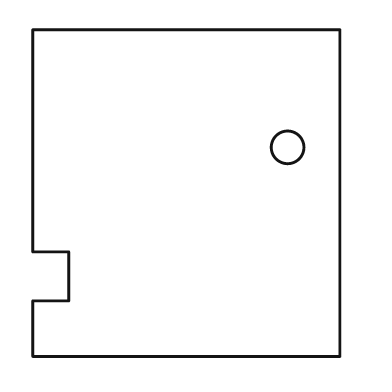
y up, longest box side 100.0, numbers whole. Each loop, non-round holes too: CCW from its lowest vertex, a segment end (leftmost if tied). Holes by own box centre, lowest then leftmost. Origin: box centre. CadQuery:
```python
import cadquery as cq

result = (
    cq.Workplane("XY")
    .moveTo(-47.0, -50.0)
    .lineTo(47.0, -50.0)
    .lineTo(47.0, 50.0)
    .lineTo(-47.0, 50.0)
    .lineTo(-47.0, -18.0)
    .lineTo(-36.0, -18.0)
    .lineTo(-36.0, -33.0)
    .lineTo(-47.0, -33.0)
    .close()
    .moveTo(31.0, 14.0)
    .circle(5.0)
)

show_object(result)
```